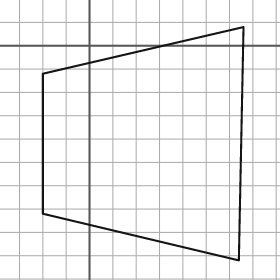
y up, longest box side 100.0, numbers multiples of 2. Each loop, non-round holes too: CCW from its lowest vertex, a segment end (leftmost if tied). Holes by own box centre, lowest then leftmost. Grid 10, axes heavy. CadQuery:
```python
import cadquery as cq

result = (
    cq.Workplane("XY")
    .moveTo(64.0, -92.0)
    .lineTo(66.0, 8.0)
    .lineTo(-20.0, -12.0)
    .lineTo(-20.0, -72.0)
    .close()
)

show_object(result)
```